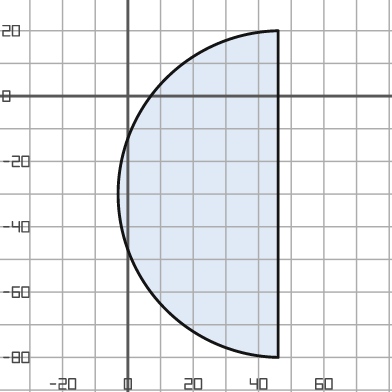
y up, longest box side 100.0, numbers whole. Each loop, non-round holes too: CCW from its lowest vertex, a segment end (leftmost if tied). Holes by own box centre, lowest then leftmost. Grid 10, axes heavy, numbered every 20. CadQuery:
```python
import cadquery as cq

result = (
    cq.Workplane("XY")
    .moveTo(46.0, -80.0)
    .lineTo(46.0, 20.0)
    .threePointArc((-3.0, -30.0), (46.0, -80.0))
    .close()
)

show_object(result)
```